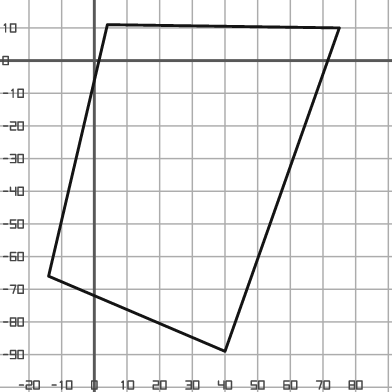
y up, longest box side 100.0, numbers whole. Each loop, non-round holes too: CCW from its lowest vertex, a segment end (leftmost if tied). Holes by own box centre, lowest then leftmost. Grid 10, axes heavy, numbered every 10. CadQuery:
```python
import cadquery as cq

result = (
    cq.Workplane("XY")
    .moveTo(40.0, -89.0)
    .lineTo(75.0, 10.0)
    .lineTo(4.0, 11.0)
    .lineTo(-14.0, -66.0)
    .close()
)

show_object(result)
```